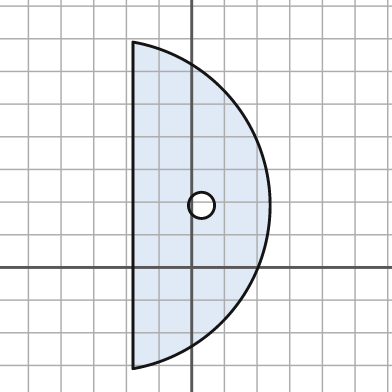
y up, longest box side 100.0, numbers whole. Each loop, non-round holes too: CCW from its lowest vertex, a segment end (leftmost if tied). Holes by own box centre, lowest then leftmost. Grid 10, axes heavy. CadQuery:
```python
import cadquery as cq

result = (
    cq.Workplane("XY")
    .moveTo(-18.0, -31.0)
    .threePointArc((24.0, 19.0), (-18.0, 69.0))
    .close()
    .moveTo(3.0, 19.0)
    .circle(4.0)
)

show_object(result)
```